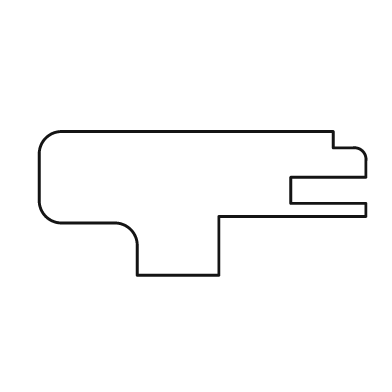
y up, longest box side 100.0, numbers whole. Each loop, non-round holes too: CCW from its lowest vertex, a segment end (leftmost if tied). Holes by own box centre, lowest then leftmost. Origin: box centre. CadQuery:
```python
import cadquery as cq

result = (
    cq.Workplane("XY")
    .moveTo(-20.0, -22.0)
    .lineTo(5.0, -22.0)
    .lineTo(5.0, -4.0)
    .lineTo(50.0, -4.0)
    .lineTo(50.0, 0.0)
    .lineTo(27.0, 0.0)
    .lineTo(27.0, 8.0)
    .lineTo(50.0, 8.0)
    .lineTo(50.0, 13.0)
    .threePointArc((49.0, 16.0), (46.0, 17.0))
    .lineTo(40.0, 17.0)
    .lineTo(40.0, 22.0)
    .lineTo(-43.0, 22.0)
    .threePointArc((-48.0, 20.0), (-50.0, 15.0))
    .lineTo(-50.0, 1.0)
    .threePointArc((-48.0, -4.0), (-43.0, -6.0))
    .lineTo(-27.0, -6.0)
    .threePointArc((-22.0, -8.0), (-20.0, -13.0))
    .close()
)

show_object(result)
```